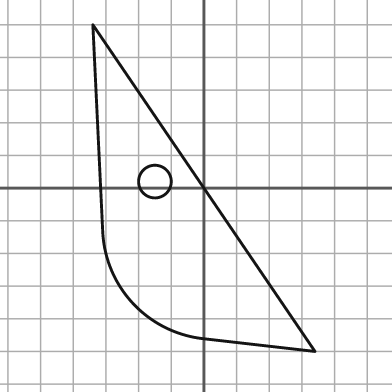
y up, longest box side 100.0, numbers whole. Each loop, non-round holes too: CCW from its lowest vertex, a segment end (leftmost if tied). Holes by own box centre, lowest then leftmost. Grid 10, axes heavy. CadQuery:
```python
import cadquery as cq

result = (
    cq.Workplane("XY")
    .moveTo(34.0, -50.0)
    .lineTo(-34.0, 50.0)
    .lineTo(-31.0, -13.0)
    .threePointArc((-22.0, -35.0), (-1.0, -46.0))
    .close()
    .moveTo(-15.0, 2.0)
    .circle(5.0)
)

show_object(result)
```